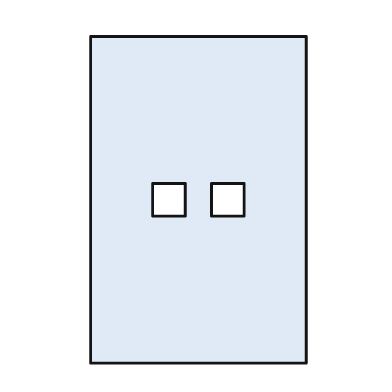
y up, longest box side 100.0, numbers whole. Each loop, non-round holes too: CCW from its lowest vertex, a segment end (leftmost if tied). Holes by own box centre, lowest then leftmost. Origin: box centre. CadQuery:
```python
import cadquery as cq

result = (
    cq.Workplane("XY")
    .moveTo(-33.0, -50.0)
    .lineTo(33.0, -50.0)
    .lineTo(33.0, 50.0)
    .lineTo(-33.0, 50.0)
    .close()
    .moveTo(-14.0, -5.0)
    .lineTo(-4.0, -5.0)
    .lineTo(-4.0, 5.0)
    .lineTo(-14.0, 5.0)
    .close()
    .moveTo(4.0, -5.0)
    .lineTo(14.0, -5.0)
    .lineTo(14.0, 5.0)
    .lineTo(4.0, 5.0)
    .close()
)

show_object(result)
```